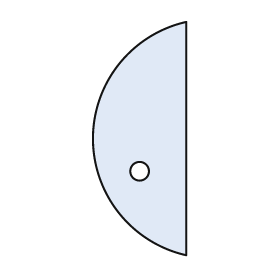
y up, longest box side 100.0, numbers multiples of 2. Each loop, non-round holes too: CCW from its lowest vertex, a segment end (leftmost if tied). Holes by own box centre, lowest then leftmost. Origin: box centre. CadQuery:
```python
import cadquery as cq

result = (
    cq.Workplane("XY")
    .moveTo(20.0, -50.0)
    .lineTo(20.0, 50.0)
    .threePointArc((-20.0, 0.0), (20.0, -50.0))
    .close()
    .moveTo(0.0, -14.0)
    .circle(4.0)
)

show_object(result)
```